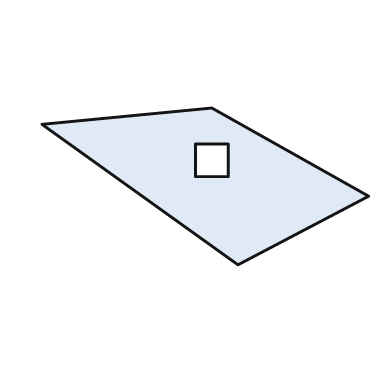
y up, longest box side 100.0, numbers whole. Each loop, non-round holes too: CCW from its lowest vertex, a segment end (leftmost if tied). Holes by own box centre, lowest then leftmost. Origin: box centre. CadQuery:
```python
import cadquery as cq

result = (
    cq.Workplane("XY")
    .moveTo(10.0, -24.0)
    .lineTo(50.0, -3.0)
    .lineTo(2.0, 24.0)
    .lineTo(-50.0, 19.0)
    .close()
    .moveTo(-3.0, 3.0)
    .lineTo(7.0, 3.0)
    .lineTo(7.0, 13.0)
    .lineTo(-3.0, 13.0)
    .close()
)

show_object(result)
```